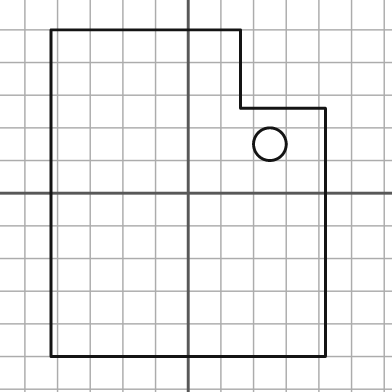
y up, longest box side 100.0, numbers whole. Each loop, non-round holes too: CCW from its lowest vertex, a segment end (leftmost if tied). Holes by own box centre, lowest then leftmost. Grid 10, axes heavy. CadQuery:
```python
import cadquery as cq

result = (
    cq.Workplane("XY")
    .moveTo(-42.0, -50.0)
    .lineTo(42.0, -50.0)
    .lineTo(42.0, 26.0)
    .lineTo(16.0, 26.0)
    .lineTo(16.0, 50.0)
    .lineTo(-42.0, 50.0)
    .close()
    .moveTo(25.0, 15.0)
    .circle(5.0)
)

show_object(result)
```